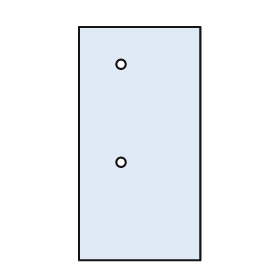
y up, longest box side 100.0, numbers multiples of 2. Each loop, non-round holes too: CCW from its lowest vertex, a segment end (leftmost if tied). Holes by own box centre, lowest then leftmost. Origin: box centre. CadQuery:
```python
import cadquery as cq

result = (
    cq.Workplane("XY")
    .moveTo(-26.0, -50.0)
    .lineTo(26.0, -50.0)
    .lineTo(26.0, 50.0)
    .lineTo(-26.0, 50.0)
    .close()
    .moveTo(-8.0, -8.0)
    .circle(2.0)
    .moveTo(-8.0, 34.0)
    .circle(2.0)
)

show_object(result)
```